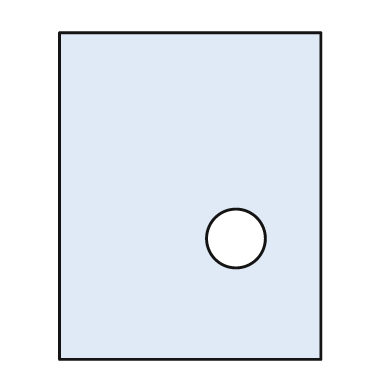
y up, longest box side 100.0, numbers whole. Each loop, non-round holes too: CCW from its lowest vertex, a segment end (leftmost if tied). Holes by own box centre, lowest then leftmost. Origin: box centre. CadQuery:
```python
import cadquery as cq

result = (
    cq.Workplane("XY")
    .moveTo(-40.0, -50.0)
    .lineTo(40.0, -50.0)
    .lineTo(40.0, 50.0)
    .lineTo(-40.0, 50.0)
    .close()
    .moveTo(14.0, -13.0)
    .circle(9.0)
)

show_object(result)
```